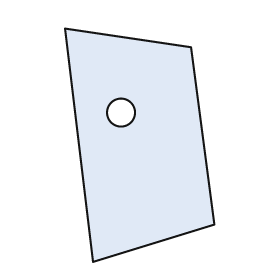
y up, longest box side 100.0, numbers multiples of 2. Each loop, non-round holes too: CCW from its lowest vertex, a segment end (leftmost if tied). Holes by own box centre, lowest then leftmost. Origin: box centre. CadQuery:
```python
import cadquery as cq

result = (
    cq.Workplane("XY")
    .moveTo(-20.0, -50.0)
    .lineTo(32.0, -34.0)
    .lineTo(22.0, 42.0)
    .lineTo(-32.0, 50.0)
    .close()
    .moveTo(-8.0, 14.0)
    .circle(6.0)
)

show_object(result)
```